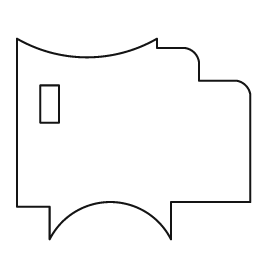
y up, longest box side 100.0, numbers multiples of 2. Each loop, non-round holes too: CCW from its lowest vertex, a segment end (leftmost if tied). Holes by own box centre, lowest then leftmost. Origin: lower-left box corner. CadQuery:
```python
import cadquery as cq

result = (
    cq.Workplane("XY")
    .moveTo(14.0, 0.0)
    .threePointArc((40.0, 16.0), (66.0, 0.0))
    .lineTo(66.0, 16.0)
    .lineTo(100.0, 16.0)
    .lineTo(100.0, 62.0)
    .threePointArc((98.0, 66.0), (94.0, 68.0))
    .lineTo(78.0, 68.0)
    .lineTo(78.0, 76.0)
    .threePointArc((76.0, 80.0), (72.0, 82.0))
    .lineTo(60.0, 82.0)
    .lineTo(60.0, 86.0)
    .threePointArc((30.0, 78.0), (0.0, 86.0))
    .lineTo(0.0, 14.0)
    .lineTo(14.0, 14.0)
    .close()
    .moveTo(10.0, 50.0)
    .lineTo(18.0, 50.0)
    .lineTo(18.0, 66.0)
    .lineTo(10.0, 66.0)
    .close()
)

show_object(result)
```